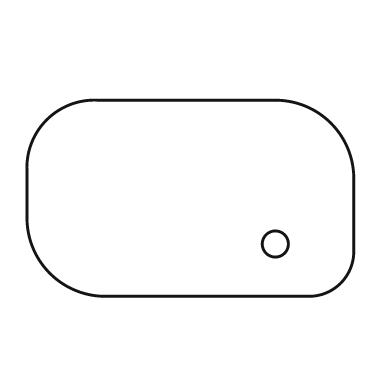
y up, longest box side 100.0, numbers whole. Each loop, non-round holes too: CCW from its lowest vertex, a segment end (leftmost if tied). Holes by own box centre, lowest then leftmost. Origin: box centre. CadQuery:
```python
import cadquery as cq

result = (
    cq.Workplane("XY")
    .moveTo(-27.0, -30.0)
    .lineTo(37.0, -30.0)
    .threePointArc((46.0, -26.0), (50.0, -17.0))
    .lineTo(50.0, 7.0)
    .threePointArc((43.0, 23.0), (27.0, 30.0))
    .lineTo(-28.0, 30.0)
    .threePointArc((-44.0, 24.0), (-50.0, 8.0))
    .lineTo(-50.0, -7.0)
    .threePointArc((-43.0, -23.0), (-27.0, -30.0))
    .close()
    .moveTo(26.0, -14.0)
    .circle(4.0)
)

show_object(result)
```